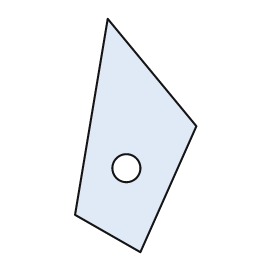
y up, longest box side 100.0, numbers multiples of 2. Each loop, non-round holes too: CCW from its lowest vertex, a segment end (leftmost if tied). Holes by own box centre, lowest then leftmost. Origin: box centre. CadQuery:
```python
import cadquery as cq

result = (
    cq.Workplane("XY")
    .moveTo(2.0, -50.0)
    .lineTo(26.0, 4.0)
    .lineTo(-12.0, 50.0)
    .lineTo(-26.0, -34.0)
    .close()
    .moveTo(-4.0, -14.0)
    .circle(6.0)
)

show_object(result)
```